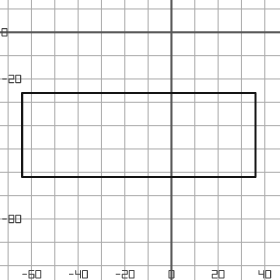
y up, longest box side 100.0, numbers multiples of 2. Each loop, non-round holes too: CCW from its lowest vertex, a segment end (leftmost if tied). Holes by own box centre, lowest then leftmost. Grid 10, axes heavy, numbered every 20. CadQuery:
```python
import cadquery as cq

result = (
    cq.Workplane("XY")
    .moveTo(-64.0, -62.0)
    .lineTo(36.0, -62.0)
    .lineTo(36.0, -26.0)
    .lineTo(-64.0, -26.0)
    .close()
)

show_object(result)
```